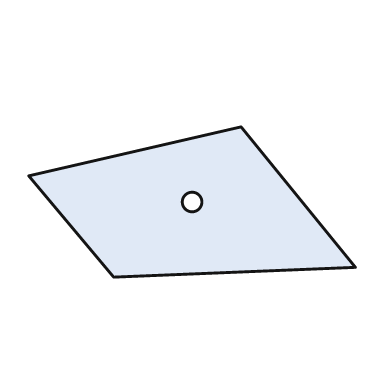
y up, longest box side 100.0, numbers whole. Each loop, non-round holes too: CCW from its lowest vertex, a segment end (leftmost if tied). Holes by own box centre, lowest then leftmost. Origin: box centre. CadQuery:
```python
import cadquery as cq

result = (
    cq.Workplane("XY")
    .moveTo(-24.0, -23.0)
    .lineTo(50.0, -20.0)
    .lineTo(15.0, 23.0)
    .lineTo(-50.0, 8.0)
    .close()
    .moveTo(0.0, 0.0)
    .circle(3.0)
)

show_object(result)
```